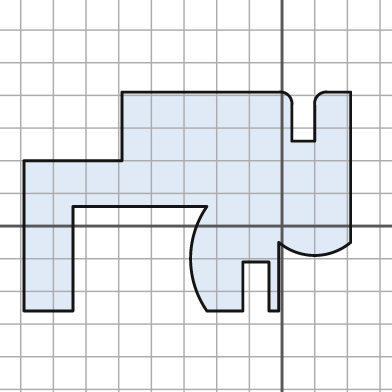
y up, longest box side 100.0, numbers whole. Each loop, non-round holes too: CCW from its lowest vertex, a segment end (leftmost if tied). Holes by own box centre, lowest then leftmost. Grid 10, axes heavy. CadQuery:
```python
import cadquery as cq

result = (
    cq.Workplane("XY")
    .moveTo(-79.0, -26.0)
    .lineTo(-64.0, -26.0)
    .lineTo(-64.0, 6.0)
    .lineTo(-23.0, 6.0)
    .threePointArc((-28.0, -10.0), (-23.0, -26.0))
    .lineTo(-12.0, -26.0)
    .lineTo(-12.0, -11.0)
    .lineTo(-4.0, -11.0)
    .lineTo(-4.0, -26.0)
    .lineTo(-1.0, -26.0)
    .lineTo(-1.0, -5.0)
    .threePointArc((10.0, -9.0), (21.0, -5.0))
    .lineTo(21.0, 41.0)
    .lineTo(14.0, 41.0)
    .threePointArc((11.0, 40.0), (10.0, 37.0))
    .lineTo(10.0, 26.0)
    .lineTo(3.0, 26.0)
    .lineTo(3.0, 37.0)
    .threePointArc((2.0, 40.0), (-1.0, 41.0))
    .lineTo(-49.0, 41.0)
    .lineTo(-49.0, 20.0)
    .lineTo(-79.0, 20.0)
    .close()
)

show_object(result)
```